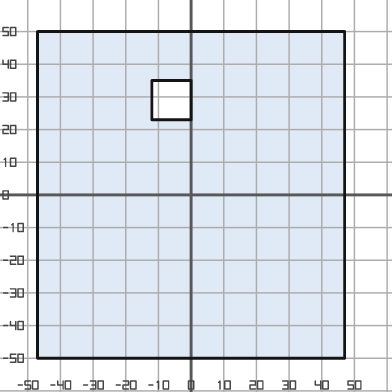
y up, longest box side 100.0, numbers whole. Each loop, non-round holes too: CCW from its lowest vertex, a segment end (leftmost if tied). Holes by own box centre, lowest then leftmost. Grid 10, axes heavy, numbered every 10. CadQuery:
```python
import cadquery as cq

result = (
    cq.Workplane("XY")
    .moveTo(-47.0, -50.0)
    .lineTo(47.0, -50.0)
    .lineTo(47.0, 50.0)
    .lineTo(-47.0, 50.0)
    .close()
    .moveTo(-12.0, 23.0)
    .lineTo(0.0, 23.0)
    .lineTo(0.0, 35.0)
    .lineTo(-12.0, 35.0)
    .close()
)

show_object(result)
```